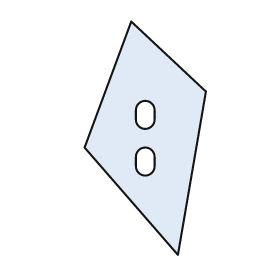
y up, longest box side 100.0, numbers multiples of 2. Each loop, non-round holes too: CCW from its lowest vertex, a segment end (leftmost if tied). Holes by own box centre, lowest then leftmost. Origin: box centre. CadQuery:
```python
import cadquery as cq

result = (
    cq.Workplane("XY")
    .moveTo(14.0, -50.0)
    .lineTo(26.0, 20.0)
    .lineTo(-6.0, 50.0)
    .lineTo(-26.0, -4.0)
    .close()
    .moveTo(-4.0, -12.0)
    .threePointArc((0.0, -16.0), (4.0, -12.0))
    .lineTo(4.0, -8.0)
    .threePointArc((0.0, -4.0), (-4.0, -8.0))
    .close()
    .moveTo(-4.0, 8.0)
    .threePointArc((0.0, 4.0), (4.0, 8.0))
    .lineTo(4.0, 12.0)
    .threePointArc((0.0, 16.0), (-4.0, 12.0))
    .close()
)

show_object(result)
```